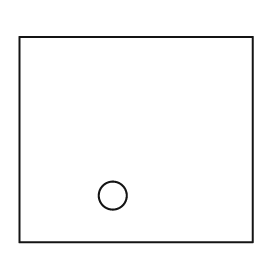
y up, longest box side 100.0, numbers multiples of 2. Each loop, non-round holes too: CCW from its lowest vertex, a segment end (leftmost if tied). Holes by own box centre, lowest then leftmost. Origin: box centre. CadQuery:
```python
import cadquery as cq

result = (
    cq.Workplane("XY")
    .moveTo(-50.0, -44.0)
    .lineTo(50.0, -44.0)
    .lineTo(50.0, 44.0)
    .lineTo(-50.0, 44.0)
    .close()
    .moveTo(-10.0, -24.0)
    .circle(6.0)
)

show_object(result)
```